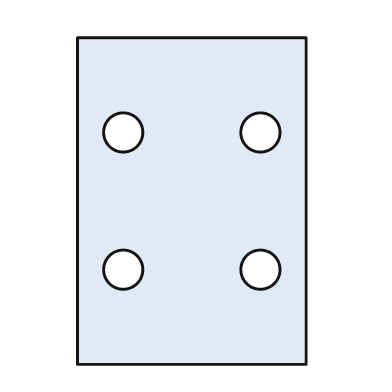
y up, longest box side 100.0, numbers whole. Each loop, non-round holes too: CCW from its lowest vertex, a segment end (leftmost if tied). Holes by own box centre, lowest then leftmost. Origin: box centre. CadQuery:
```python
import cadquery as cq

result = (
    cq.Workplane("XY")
    .moveTo(-35.0, -50.0)
    .lineTo(35.0, -50.0)
    .lineTo(35.0, 50.0)
    .lineTo(-35.0, 50.0)
    .close()
    .moveTo(-21.0, -21.0)
    .circle(6.0)
    .moveTo(21.0, -21.0)
    .circle(6.0)
    .moveTo(-21.0, 21.0)
    .circle(6.0)
    .moveTo(21.0, 21.0)
    .circle(6.0)
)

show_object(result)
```